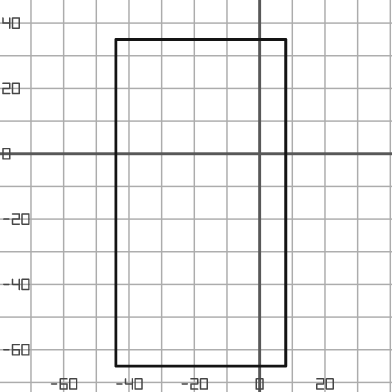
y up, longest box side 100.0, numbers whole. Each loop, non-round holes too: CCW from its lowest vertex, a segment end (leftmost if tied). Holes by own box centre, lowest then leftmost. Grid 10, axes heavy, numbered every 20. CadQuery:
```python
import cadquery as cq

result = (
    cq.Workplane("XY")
    .moveTo(-44.0, -65.0)
    .lineTo(8.0, -65.0)
    .lineTo(8.0, 35.0)
    .lineTo(-44.0, 35.0)
    .close()
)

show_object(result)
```